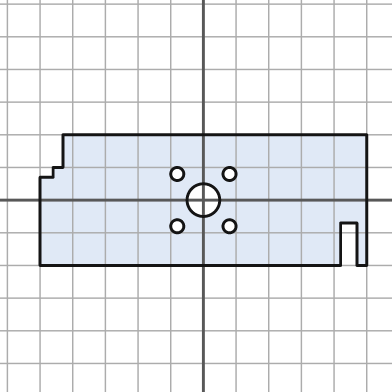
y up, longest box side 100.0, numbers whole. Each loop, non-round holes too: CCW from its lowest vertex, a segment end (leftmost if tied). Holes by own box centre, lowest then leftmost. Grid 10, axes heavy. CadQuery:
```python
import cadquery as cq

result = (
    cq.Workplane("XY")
    .moveTo(-50.0, -20.0)
    .lineTo(42.0, -20.0)
    .lineTo(42.0, -7.0)
    .lineTo(47.0, -7.0)
    .lineTo(47.0, -20.0)
    .lineTo(50.0, -20.0)
    .lineTo(50.0, 20.0)
    .lineTo(-43.0, 20.0)
    .lineTo(-43.0, 10.0)
    .lineTo(-46.0, 10.0)
    .lineTo(-46.0, 7.0)
    .lineTo(-50.0, 7.0)
    .close()
    .moveTo(-8.0, -8.0)
    .circle(2.0)
    .moveTo(8.0, -8.0)
    .circle(2.0)
    .moveTo(0.0, 0.0)
    .circle(5.0)
    .moveTo(-8.0, 8.0)
    .circle(2.0)
    .moveTo(8.0, 8.0)
    .circle(2.0)
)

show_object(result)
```